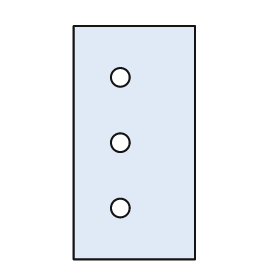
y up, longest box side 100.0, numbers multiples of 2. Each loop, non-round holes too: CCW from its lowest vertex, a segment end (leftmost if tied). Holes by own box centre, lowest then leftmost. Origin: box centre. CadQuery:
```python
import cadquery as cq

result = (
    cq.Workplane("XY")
    .moveTo(-26.0, -50.0)
    .lineTo(26.0, -50.0)
    .lineTo(26.0, 50.0)
    .lineTo(-26.0, 50.0)
    .close()
    .moveTo(-6.0, -28.0)
    .circle(4.0)
    .moveTo(-6.0, 0.0)
    .circle(4.0)
    .moveTo(-6.0, 28.0)
    .circle(4.0)
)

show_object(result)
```